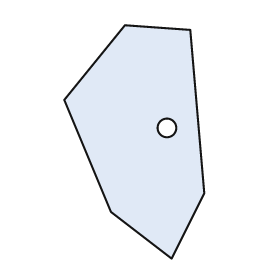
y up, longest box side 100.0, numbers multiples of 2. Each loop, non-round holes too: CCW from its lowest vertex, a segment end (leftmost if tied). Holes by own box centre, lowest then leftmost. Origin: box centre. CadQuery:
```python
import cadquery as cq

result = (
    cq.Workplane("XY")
    .moveTo(16.0, -50.0)
    .lineTo(30.0, -22.0)
    .lineTo(24.0, 48.0)
    .lineTo(-4.0, 50.0)
    .lineTo(-30.0, 18.0)
    .lineTo(-10.0, -30.0)
    .close()
    .moveTo(14.0, 6.0)
    .circle(4.0)
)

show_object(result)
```